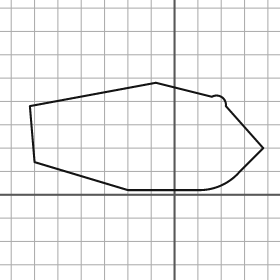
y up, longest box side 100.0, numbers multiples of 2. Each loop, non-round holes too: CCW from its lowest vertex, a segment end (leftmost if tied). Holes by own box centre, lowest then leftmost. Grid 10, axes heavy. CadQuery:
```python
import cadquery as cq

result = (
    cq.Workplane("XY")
    .moveTo(-20.0, 2.0)
    .lineTo(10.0, 2.0)
    .threePointArc((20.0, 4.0), (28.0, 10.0))
    .lineTo(38.0, 20.0)
    .lineTo(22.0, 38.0)
    .threePointArc((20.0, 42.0), (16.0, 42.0))
    .lineTo(-8.0, 48.0)
    .lineTo(-62.0, 38.0)
    .lineTo(-60.0, 14.0)
    .close()
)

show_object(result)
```